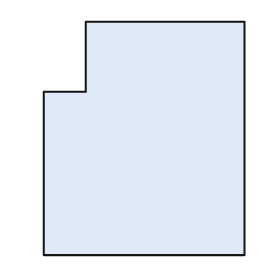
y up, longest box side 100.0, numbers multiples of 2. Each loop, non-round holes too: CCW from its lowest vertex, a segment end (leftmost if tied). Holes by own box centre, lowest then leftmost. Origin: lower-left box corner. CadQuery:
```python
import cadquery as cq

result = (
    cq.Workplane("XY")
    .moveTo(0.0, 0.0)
    .lineTo(86.0, 0.0)
    .lineTo(86.0, 100.0)
    .lineTo(18.0, 100.0)
    .lineTo(18.0, 70.0)
    .lineTo(0.0, 70.0)
    .close()
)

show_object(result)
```